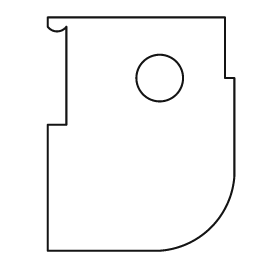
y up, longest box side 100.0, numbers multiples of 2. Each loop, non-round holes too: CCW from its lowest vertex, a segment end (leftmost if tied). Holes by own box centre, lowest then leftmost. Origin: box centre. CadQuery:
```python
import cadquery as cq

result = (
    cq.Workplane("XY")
    .moveTo(-40.0, -50.0)
    .lineTo(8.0, -50.0)
    .threePointArc((30.0, -40.0), (40.0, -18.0))
    .lineTo(40.0, 24.0)
    .lineTo(36.0, 24.0)
    .lineTo(36.0, 50.0)
    .lineTo(-40.0, 50.0)
    .lineTo(-40.0, 46.0)
    .threePointArc((-36.0, 44.0), (-32.0, 46.0))
    .lineTo(-32.0, 4.0)
    .lineTo(-40.0, 4.0)
    .close()
    .moveTo(8.0, 24.0)
    .circle(10.0)
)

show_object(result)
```